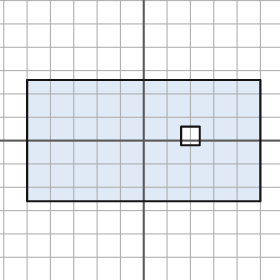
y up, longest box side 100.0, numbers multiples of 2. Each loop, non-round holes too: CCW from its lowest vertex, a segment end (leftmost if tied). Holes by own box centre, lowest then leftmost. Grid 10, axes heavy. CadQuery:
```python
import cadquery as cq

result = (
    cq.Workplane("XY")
    .moveTo(-50.0, -26.0)
    .lineTo(50.0, -26.0)
    .lineTo(50.0, 26.0)
    .lineTo(-50.0, 26.0)
    .close()
    .moveTo(16.0, -2.0)
    .lineTo(24.0, -2.0)
    .lineTo(24.0, 6.0)
    .lineTo(16.0, 6.0)
    .close()
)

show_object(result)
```